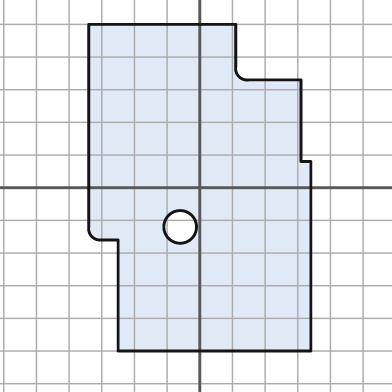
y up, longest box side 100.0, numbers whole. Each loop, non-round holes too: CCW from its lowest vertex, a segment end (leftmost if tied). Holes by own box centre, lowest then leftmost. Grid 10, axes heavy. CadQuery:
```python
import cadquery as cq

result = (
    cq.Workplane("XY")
    .moveTo(-25.0, -50.0)
    .lineTo(34.0, -50.0)
    .lineTo(34.0, 8.0)
    .lineTo(31.0, 8.0)
    .lineTo(31.0, 33.0)
    .lineTo(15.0, 33.0)
    .threePointArc((12.0, 34.0), (11.0, 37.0))
    .lineTo(11.0, 50.0)
    .lineTo(-34.0, 50.0)
    .lineTo(-34.0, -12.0)
    .threePointArc((-33.0, -15.0), (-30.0, -16.0))
    .lineTo(-25.0, -16.0)
    .close()
    .moveTo(-6.0, -12.0)
    .circle(5.0)
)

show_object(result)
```